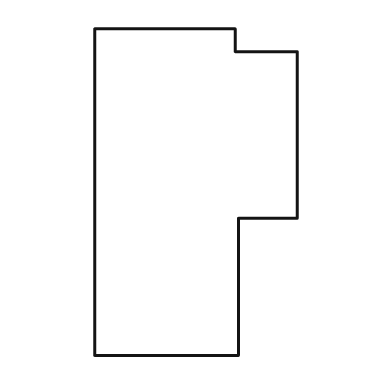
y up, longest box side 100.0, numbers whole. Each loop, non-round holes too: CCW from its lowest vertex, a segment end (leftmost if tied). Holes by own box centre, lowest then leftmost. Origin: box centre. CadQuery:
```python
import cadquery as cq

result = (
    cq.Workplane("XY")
    .moveTo(-31.0, -50.0)
    .lineTo(13.0, -50.0)
    .lineTo(13.0, -8.0)
    .lineTo(31.0, -8.0)
    .lineTo(31.0, 43.0)
    .lineTo(12.0, 43.0)
    .lineTo(12.0, 50.0)
    .lineTo(-31.0, 50.0)
    .close()
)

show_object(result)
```